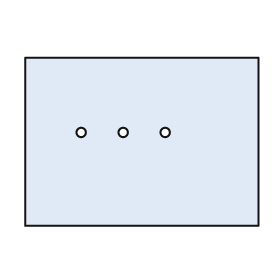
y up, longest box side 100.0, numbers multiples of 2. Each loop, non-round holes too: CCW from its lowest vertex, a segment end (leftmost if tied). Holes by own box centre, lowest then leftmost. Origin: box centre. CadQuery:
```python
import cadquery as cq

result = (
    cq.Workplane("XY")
    .moveTo(-50.0, -36.0)
    .lineTo(50.0, -36.0)
    .lineTo(50.0, 36.0)
    .lineTo(-50.0, 36.0)
    .close()
    .moveTo(-26.0, 4.0)
    .circle(2.0)
    .moveTo(-8.0, 4.0)
    .circle(2.0)
    .moveTo(10.0, 4.0)
    .circle(2.0)
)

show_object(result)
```